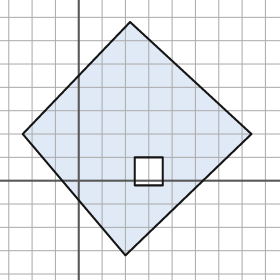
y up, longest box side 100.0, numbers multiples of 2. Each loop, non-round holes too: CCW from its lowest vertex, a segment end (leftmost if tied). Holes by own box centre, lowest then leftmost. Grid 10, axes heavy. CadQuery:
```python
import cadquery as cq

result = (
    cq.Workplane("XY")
    .moveTo(20.0, -32.0)
    .lineTo(74.0, 20.0)
    .lineTo(22.0, 68.0)
    .lineTo(-24.0, 20.0)
    .close()
    .moveTo(24.0, -2.0)
    .lineTo(36.0, -2.0)
    .lineTo(36.0, 10.0)
    .lineTo(24.0, 10.0)
    .close()
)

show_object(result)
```